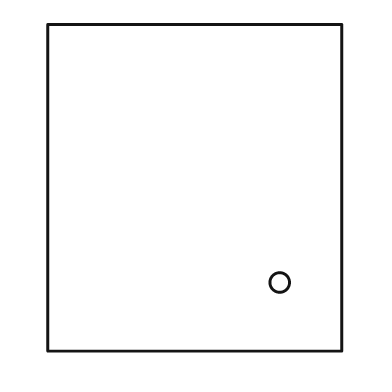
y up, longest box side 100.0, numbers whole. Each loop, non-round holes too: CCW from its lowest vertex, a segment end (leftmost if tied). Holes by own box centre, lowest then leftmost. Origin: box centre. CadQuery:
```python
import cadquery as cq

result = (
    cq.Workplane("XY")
    .moveTo(-45.0, -50.0)
    .lineTo(45.0, -50.0)
    .lineTo(45.0, 50.0)
    .lineTo(-45.0, 50.0)
    .close()
    .moveTo(26.0, -29.0)
    .circle(3.0)
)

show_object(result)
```